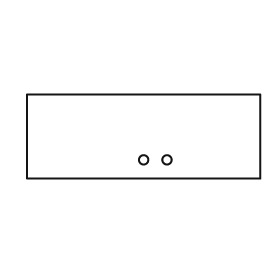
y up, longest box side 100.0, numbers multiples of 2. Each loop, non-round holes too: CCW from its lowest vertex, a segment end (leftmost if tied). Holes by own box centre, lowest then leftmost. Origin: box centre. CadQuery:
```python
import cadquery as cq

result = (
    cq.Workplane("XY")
    .moveTo(-50.0, -18.0)
    .lineTo(50.0, -18.0)
    .lineTo(50.0, 18.0)
    .lineTo(-50.0, 18.0)
    .close()
    .moveTo(0.0, -10.0)
    .circle(2.0)
    .moveTo(10.0, -10.0)
    .circle(2.0)
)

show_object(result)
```